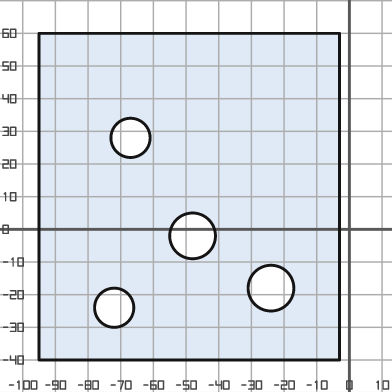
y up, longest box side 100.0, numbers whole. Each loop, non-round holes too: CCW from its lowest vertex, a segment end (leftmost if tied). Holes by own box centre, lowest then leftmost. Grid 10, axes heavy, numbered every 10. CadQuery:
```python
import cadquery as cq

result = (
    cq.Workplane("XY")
    .moveTo(-95.0, -40.0)
    .lineTo(-3.0, -40.0)
    .lineTo(-3.0, 60.0)
    .lineTo(-95.0, 60.0)
    .close()
    .moveTo(-72.0, -24.0)
    .circle(6.0)
    .moveTo(-24.0, -18.0)
    .circle(7.0)
    .moveTo(-48.0, -2.0)
    .circle(7.0)
    .moveTo(-67.0, 28.0)
    .circle(6.0)
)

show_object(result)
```